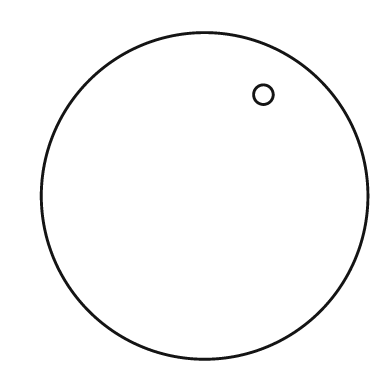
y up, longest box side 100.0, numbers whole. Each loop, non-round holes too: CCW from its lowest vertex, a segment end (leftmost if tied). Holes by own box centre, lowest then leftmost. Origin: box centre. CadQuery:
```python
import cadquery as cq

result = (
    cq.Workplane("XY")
    .moveTo(0.0, 0.0)
    .circle(50.0)
    .moveTo(18.0, 31.0)
    .circle(3.0)
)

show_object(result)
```